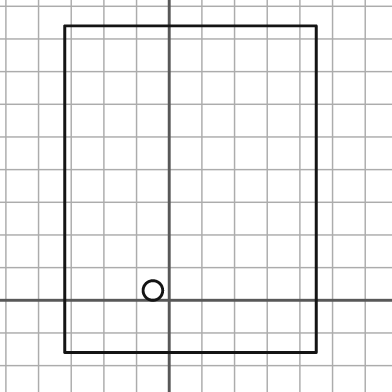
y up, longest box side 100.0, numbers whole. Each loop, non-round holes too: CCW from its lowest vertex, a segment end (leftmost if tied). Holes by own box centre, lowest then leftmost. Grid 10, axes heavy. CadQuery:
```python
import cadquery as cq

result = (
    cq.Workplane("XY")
    .moveTo(-32.0, -16.0)
    .lineTo(45.0, -16.0)
    .lineTo(45.0, 84.0)
    .lineTo(-32.0, 84.0)
    .close()
    .moveTo(-5.0, 3.0)
    .circle(3.0)
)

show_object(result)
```